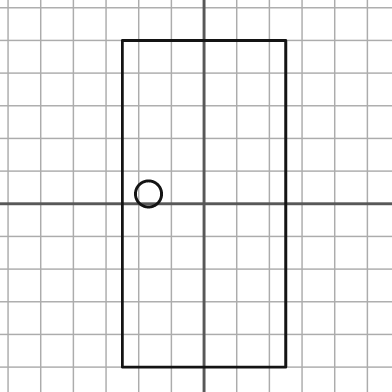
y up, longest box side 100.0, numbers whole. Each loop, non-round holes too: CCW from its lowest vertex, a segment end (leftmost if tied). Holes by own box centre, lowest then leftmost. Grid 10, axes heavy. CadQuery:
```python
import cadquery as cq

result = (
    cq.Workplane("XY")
    .moveTo(-25.0, -50.0)
    .lineTo(25.0, -50.0)
    .lineTo(25.0, 50.0)
    .lineTo(-25.0, 50.0)
    .close()
    .moveTo(-17.0, 3.0)
    .circle(4.0)
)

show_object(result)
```